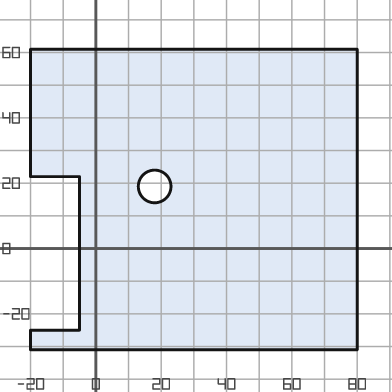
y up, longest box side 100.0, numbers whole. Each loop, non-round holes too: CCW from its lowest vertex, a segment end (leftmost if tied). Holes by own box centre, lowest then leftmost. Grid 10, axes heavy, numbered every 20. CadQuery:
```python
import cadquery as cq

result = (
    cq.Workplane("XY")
    .moveTo(-20.0, -31.0)
    .lineTo(80.0, -31.0)
    .lineTo(80.0, 61.0)
    .lineTo(-20.0, 61.0)
    .lineTo(-20.0, 22.0)
    .lineTo(-5.0, 22.0)
    .lineTo(-5.0, -25.0)
    .lineTo(-20.0, -25.0)
    .close()
    .moveTo(18.0, 19.0)
    .circle(5.0)
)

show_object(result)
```